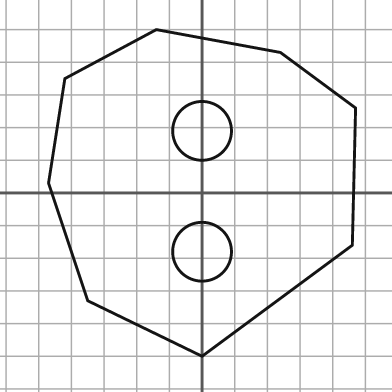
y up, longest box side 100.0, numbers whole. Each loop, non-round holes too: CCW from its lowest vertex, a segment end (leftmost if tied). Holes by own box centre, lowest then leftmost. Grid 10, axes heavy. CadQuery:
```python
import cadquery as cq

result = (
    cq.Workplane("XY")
    .moveTo(0.0, -50.0)
    .lineTo(46.0, -16.0)
    .lineTo(47.0, 26.0)
    .lineTo(24.0, 43.0)
    .lineTo(-14.0, 50.0)
    .lineTo(-42.0, 35.0)
    .lineTo(-47.0, 3.0)
    .lineTo(-35.0, -33.0)
    .close()
    .moveTo(0.0, -18.0)
    .circle(9.0)
    .moveTo(0.0, 19.0)
    .circle(9.0)
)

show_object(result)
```